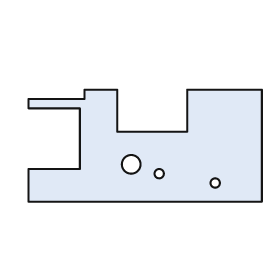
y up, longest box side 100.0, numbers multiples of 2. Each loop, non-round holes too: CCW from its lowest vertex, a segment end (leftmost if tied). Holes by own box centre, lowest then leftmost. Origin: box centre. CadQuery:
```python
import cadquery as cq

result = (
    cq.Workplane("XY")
    .moveTo(-50.0, -24.0)
    .lineTo(50.0, -24.0)
    .lineTo(50.0, 24.0)
    .lineTo(18.0, 24.0)
    .lineTo(18.0, 6.0)
    .lineTo(-12.0, 6.0)
    .lineTo(-12.0, 24.0)
    .lineTo(-26.0, 24.0)
    .lineTo(-26.0, 20.0)
    .lineTo(-50.0, 20.0)
    .lineTo(-50.0, 16.0)
    .lineTo(-28.0, 16.0)
    .lineTo(-28.0, -10.0)
    .lineTo(-50.0, -10.0)
    .close()
    .moveTo(30.0, -16.0)
    .circle(2.0)
    .moveTo(6.0, -12.0)
    .circle(2.0)
    .moveTo(-6.0, -8.0)
    .circle(4.0)
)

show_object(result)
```